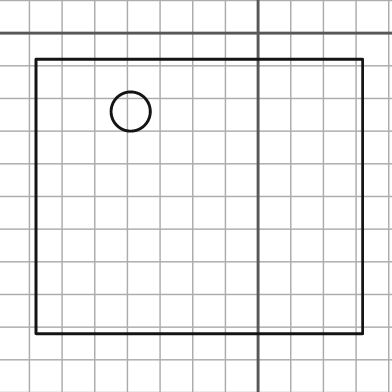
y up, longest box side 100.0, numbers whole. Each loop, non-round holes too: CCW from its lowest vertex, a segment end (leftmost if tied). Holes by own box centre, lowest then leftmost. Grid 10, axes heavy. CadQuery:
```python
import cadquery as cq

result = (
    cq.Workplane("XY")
    .moveTo(-68.0, -92.0)
    .lineTo(32.0, -92.0)
    .lineTo(32.0, -8.0)
    .lineTo(-68.0, -8.0)
    .close()
    .moveTo(-39.0, -24.0)
    .circle(6.0)
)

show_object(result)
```